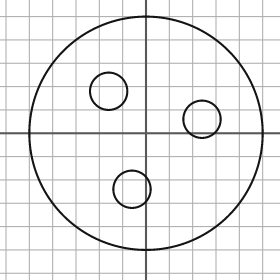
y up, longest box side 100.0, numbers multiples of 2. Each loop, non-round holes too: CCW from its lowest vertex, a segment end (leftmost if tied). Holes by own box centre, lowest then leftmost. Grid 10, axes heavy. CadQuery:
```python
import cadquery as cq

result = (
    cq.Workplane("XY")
    .moveTo(0.0, 0.0)
    .circle(50.0)
    .moveTo(-6.0, -24.0)
    .circle(8.0)
    .moveTo(24.0, 6.0)
    .circle(8.0)
    .moveTo(-16.0, 18.0)
    .circle(8.0)
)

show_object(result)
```